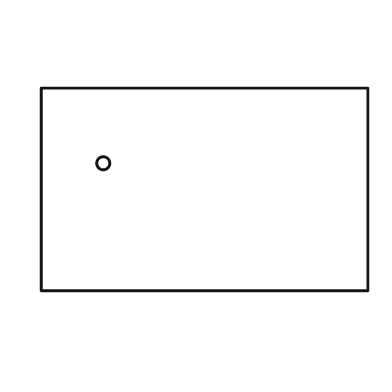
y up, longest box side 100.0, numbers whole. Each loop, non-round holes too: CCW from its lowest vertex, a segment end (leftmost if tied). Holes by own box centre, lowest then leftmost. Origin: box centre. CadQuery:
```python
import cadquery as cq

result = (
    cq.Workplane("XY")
    .moveTo(-50.0, -31.0)
    .lineTo(50.0, -31.0)
    .lineTo(50.0, 31.0)
    .lineTo(-50.0, 31.0)
    .close()
    .moveTo(-31.0, 8.0)
    .circle(2.0)
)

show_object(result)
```